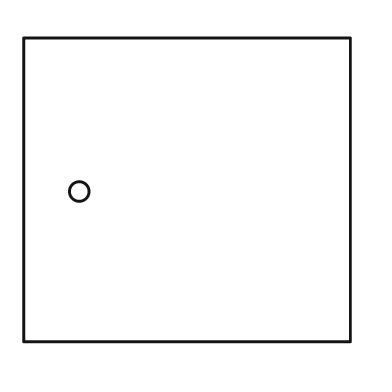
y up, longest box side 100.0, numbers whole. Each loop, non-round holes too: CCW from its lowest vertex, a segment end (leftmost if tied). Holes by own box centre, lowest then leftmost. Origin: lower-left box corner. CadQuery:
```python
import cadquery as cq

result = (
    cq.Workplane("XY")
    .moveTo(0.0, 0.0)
    .lineTo(100.0, 0.0)
    .lineTo(100.0, 93.0)
    .lineTo(0.0, 93.0)
    .close()
    .moveTo(17.0, 46.0)
    .circle(3.0)
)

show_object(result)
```